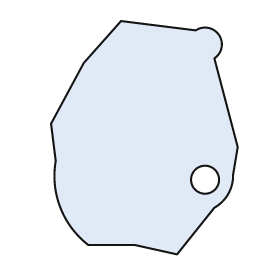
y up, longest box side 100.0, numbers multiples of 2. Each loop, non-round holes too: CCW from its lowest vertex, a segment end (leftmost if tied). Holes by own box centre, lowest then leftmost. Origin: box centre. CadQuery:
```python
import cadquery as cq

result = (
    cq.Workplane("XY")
    .moveTo(14.0, -50.0)
    .lineTo(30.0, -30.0)
    .threePointArc((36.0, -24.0), (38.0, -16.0))
    .lineTo(40.0, -4.0)
    .lineTo(30.0, 34.0)
    .threePointArc((32.0, 44.0), (22.0, 46.0))
    .lineTo(-10.0, 50.0)
    .lineTo(-26.0, 32.0)
    .lineTo(-40.0, 6.0)
    .lineTo(-38.0, -10.0)
    .threePointArc((-36.0, -30.0), (-24.0, -46.0))
    .lineTo(-4.0, -46.0)
    .close()
    .moveTo(26.0, -18.0)
    .circle(6.0)
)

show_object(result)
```